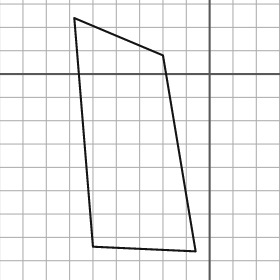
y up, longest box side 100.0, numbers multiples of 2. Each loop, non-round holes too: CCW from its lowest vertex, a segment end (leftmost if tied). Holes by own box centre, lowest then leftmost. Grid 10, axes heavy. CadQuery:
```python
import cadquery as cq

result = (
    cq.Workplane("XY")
    .moveTo(-6.0, -76.0)
    .lineTo(-20.0, 8.0)
    .lineTo(-58.0, 24.0)
    .lineTo(-50.0, -74.0)
    .close()
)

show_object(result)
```